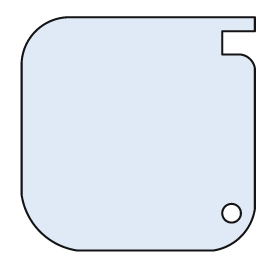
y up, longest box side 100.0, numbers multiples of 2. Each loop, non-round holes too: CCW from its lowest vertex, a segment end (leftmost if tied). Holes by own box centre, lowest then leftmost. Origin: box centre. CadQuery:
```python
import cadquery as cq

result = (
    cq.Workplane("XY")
    .moveTo(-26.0, -50.0)
    .lineTo(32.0, -50.0)
    .threePointArc((44.0, -44.0), (50.0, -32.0))
    .lineTo(50.0, 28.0)
    .threePointArc((48.0, 32.0), (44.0, 34.0))
    .lineTo(36.0, 34.0)
    .lineTo(36.0, 44.0)
    .lineTo(50.0, 44.0)
    .lineTo(50.0, 50.0)
    .lineTo(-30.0, 50.0)
    .threePointArc((-44.0, 44.0), (-50.0, 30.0))
    .lineTo(-50.0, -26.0)
    .threePointArc((-42.0, -42.0), (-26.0, -50.0))
    .close()
    .moveTo(40.0, -34.0)
    .circle(4.0)
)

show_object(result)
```